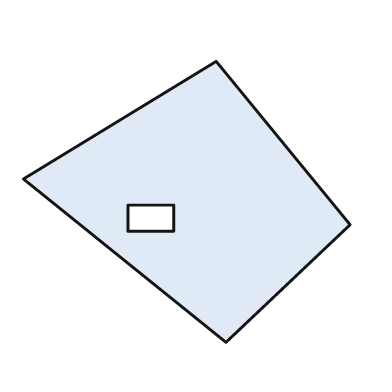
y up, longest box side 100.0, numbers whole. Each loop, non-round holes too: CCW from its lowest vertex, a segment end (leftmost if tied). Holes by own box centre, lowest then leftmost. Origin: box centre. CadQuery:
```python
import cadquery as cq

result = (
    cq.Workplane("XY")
    .moveTo(12.0, -43.0)
    .lineTo(50.0, -7.0)
    .lineTo(9.0, 43.0)
    .lineTo(-50.0, 7.0)
    .close()
    .moveTo(-18.0, -9.0)
    .lineTo(-4.0, -9.0)
    .lineTo(-4.0, -1.0)
    .lineTo(-18.0, -1.0)
    .close()
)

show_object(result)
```